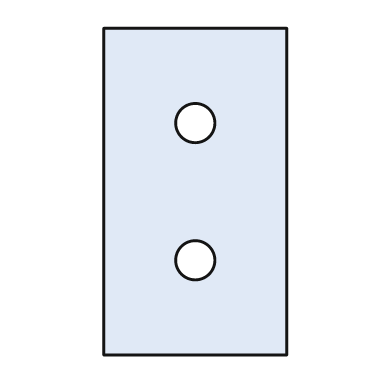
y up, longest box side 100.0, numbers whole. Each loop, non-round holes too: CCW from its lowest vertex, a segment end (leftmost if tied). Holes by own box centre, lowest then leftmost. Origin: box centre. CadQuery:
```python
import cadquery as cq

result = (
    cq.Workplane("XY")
    .moveTo(-28.0, -50.0)
    .lineTo(28.0, -50.0)
    .lineTo(28.0, 50.0)
    .lineTo(-28.0, 50.0)
    .close()
    .moveTo(0.0, -21.0)
    .circle(6.0)
    .moveTo(0.0, 21.0)
    .circle(6.0)
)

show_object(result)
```